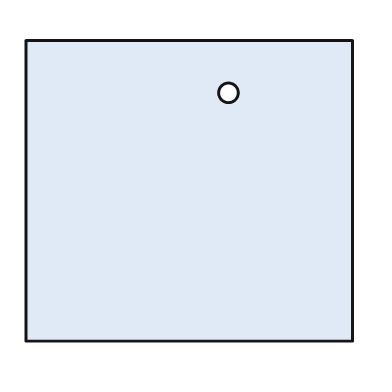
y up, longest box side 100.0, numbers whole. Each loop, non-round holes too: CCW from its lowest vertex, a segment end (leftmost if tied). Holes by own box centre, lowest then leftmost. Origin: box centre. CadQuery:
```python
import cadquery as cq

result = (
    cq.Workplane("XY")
    .moveTo(-50.0, -46.0)
    .lineTo(50.0, -46.0)
    .lineTo(50.0, 46.0)
    .lineTo(-50.0, 46.0)
    .close()
    .moveTo(12.0, 30.0)
    .circle(3.0)
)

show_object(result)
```